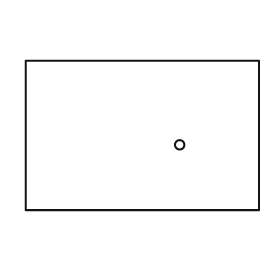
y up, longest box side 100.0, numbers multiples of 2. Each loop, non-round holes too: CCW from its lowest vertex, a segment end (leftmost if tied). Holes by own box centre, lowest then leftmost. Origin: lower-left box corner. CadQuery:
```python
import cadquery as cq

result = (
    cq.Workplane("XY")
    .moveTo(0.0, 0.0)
    .lineTo(100.0, 0.0)
    .lineTo(100.0, 64.0)
    .lineTo(0.0, 64.0)
    .close()
    .moveTo(66.0, 28.0)
    .circle(2.0)
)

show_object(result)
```